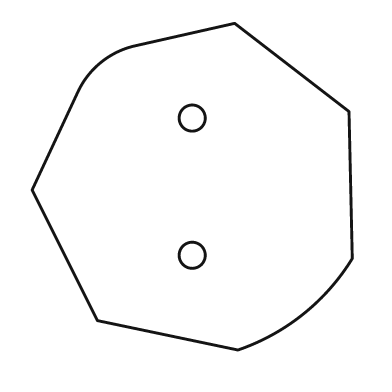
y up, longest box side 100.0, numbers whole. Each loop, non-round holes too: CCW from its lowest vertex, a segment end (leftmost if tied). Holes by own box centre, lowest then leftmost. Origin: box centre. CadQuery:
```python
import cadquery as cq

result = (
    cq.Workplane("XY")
    .moveTo(14.0, -50.0)
    .threePointArc((34.0, -39.0), (49.0, -22.0))
    .lineTo(48.0, 23.0)
    .lineTo(13.0, 50.0)
    .lineTo(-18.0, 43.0)
    .threePointArc((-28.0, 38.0), (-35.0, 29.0))
    .lineTo(-49.0, -1.0)
    .lineTo(-29.0, -41.0)
    .close()
    .moveTo(0.0, -21.0)
    .circle(4.0)
    .moveTo(0.0, 21.0)
    .circle(4.0)
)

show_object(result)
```